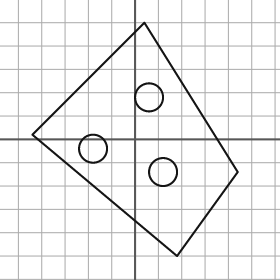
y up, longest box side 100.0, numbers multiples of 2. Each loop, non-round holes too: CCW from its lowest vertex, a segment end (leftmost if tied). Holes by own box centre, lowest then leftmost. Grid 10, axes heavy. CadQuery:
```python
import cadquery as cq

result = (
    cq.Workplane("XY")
    .moveTo(18.0, -50.0)
    .lineTo(44.0, -14.0)
    .lineTo(4.0, 50.0)
    .lineTo(-44.0, 2.0)
    .close()
    .moveTo(12.0, -14.0)
    .circle(6.0)
    .moveTo(-18.0, -4.0)
    .circle(6.0)
    .moveTo(6.0, 18.0)
    .circle(6.0)
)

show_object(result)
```